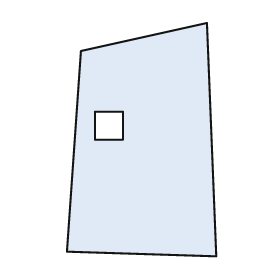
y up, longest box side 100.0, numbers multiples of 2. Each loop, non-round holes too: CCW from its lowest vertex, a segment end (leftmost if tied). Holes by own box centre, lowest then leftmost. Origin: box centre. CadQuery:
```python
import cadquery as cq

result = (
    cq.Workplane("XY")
    .moveTo(32.0, -50.0)
    .lineTo(28.0, 50.0)
    .lineTo(-26.0, 38.0)
    .lineTo(-32.0, -48.0)
    .close()
    .moveTo(-20.0, 0.0)
    .lineTo(-8.0, 0.0)
    .lineTo(-8.0, 12.0)
    .lineTo(-20.0, 12.0)
    .close()
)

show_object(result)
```